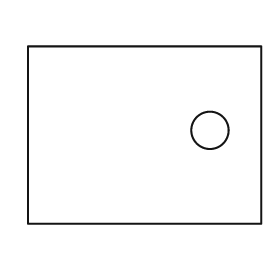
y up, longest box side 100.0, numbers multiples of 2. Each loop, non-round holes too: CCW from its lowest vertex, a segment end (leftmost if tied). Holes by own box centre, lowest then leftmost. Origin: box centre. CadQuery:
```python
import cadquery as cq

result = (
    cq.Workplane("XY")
    .moveTo(-50.0, -38.0)
    .lineTo(50.0, -38.0)
    .lineTo(50.0, 38.0)
    .lineTo(-50.0, 38.0)
    .close()
    .moveTo(28.0, 2.0)
    .circle(8.0)
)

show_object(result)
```